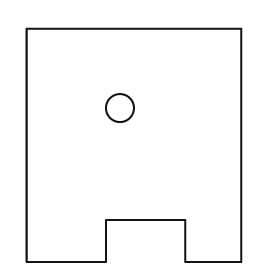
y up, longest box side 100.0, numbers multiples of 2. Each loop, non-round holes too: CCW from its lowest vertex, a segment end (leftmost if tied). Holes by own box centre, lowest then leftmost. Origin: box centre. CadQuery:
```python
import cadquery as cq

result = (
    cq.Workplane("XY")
    .moveTo(-46.0, -50.0)
    .lineTo(-12.0, -50.0)
    .lineTo(-12.0, -32.0)
    .lineTo(22.0, -32.0)
    .lineTo(22.0, -50.0)
    .lineTo(46.0, -50.0)
    .lineTo(46.0, 50.0)
    .lineTo(-46.0, 50.0)
    .close()
    .moveTo(-6.0, 16.0)
    .circle(6.0)
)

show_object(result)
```